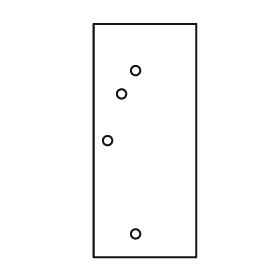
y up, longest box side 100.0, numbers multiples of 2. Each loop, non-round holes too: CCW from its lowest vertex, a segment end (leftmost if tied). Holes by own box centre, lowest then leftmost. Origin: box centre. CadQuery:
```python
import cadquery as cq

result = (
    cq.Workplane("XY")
    .moveTo(-22.0, -50.0)
    .lineTo(22.0, -50.0)
    .lineTo(22.0, 50.0)
    .lineTo(-22.0, 50.0)
    .close()
    .moveTo(-4.0, -40.0)
    .circle(2.0)
    .moveTo(-16.0, 0.0)
    .circle(2.0)
    .moveTo(-10.0, 20.0)
    .circle(2.0)
    .moveTo(-4.0, 30.0)
    .circle(2.0)
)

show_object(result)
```